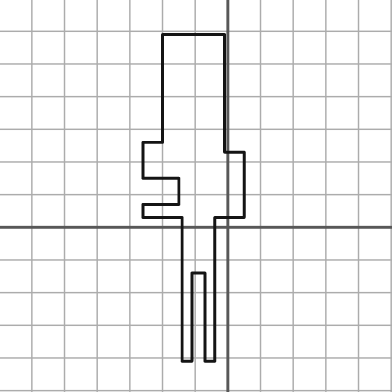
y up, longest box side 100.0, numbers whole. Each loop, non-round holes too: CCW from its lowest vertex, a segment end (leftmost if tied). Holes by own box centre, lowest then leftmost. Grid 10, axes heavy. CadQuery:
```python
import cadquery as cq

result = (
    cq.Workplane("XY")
    .moveTo(-14.0, -41.0)
    .lineTo(-11.0, -41.0)
    .lineTo(-11.0, -14.0)
    .lineTo(-7.0, -14.0)
    .lineTo(-7.0, -41.0)
    .lineTo(-4.0, -41.0)
    .lineTo(-4.0, 3.0)
    .lineTo(5.0, 3.0)
    .lineTo(5.0, 23.0)
    .lineTo(-1.0, 23.0)
    .lineTo(-1.0, 59.0)
    .lineTo(-20.0, 59.0)
    .lineTo(-20.0, 26.0)
    .lineTo(-26.0, 26.0)
    .lineTo(-26.0, 15.0)
    .lineTo(-15.0, 15.0)
    .lineTo(-15.0, 7.0)
    .lineTo(-26.0, 7.0)
    .lineTo(-26.0, 3.0)
    .lineTo(-14.0, 3.0)
    .close()
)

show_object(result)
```